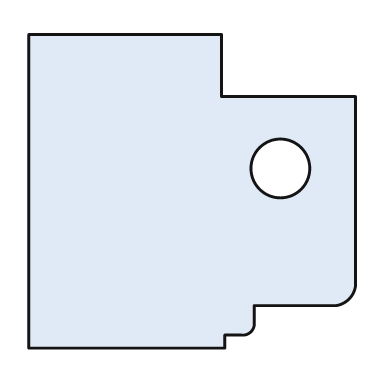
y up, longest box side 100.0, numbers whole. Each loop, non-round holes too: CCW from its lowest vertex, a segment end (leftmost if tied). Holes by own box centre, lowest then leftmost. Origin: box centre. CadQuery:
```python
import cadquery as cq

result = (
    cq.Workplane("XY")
    .moveTo(-50.0, -48.0)
    .lineTo(10.0, -48.0)
    .lineTo(10.0, -44.0)
    .lineTo(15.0, -44.0)
    .threePointArc((18.0, -43.0), (19.0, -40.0))
    .lineTo(19.0, -35.0)
    .lineTo(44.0, -35.0)
    .threePointArc((48.0, -33.0), (50.0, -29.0))
    .lineTo(50.0, 29.0)
    .lineTo(9.0, 29.0)
    .lineTo(9.0, 48.0)
    .lineTo(-50.0, 48.0)
    .close()
    .moveTo(27.0, 7.0)
    .circle(9.0)
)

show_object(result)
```